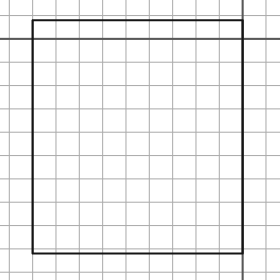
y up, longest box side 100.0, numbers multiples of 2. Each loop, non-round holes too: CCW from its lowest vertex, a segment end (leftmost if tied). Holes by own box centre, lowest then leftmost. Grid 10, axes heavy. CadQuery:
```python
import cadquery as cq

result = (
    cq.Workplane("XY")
    .moveTo(-90.0, -92.0)
    .lineTo(0.0, -92.0)
    .lineTo(0.0, 8.0)
    .lineTo(-90.0, 8.0)
    .close()
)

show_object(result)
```